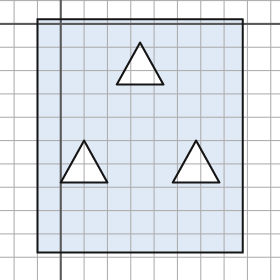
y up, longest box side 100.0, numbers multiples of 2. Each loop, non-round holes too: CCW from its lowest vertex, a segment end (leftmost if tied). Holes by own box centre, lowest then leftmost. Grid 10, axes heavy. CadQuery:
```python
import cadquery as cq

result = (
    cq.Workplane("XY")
    .moveTo(-10.0, -98.0)
    .lineTo(78.0, -98.0)
    .lineTo(78.0, 2.0)
    .lineTo(-10.0, 2.0)
    .close()
    .moveTo(0.0, -68.0)
    .lineTo(20.0, -68.0)
    .lineTo(10.0, -50.0)
    .close()
    .moveTo(48.0, -68.0)
    .lineTo(68.0, -68.0)
    .lineTo(58.0, -50.0)
    .close()
    .moveTo(24.0, -26.0)
    .lineTo(44.0, -26.0)
    .lineTo(34.0, -8.0)
    .close()
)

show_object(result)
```